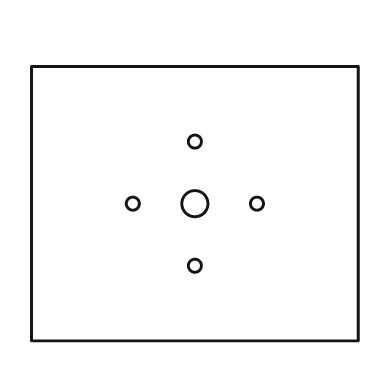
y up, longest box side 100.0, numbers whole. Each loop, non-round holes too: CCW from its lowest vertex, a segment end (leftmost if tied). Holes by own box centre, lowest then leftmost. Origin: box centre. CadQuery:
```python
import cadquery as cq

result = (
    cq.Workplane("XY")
    .moveTo(-50.0, -42.0)
    .lineTo(50.0, -42.0)
    .lineTo(50.0, 42.0)
    .lineTo(-50.0, 42.0)
    .close()
    .moveTo(0.0, -19.0)
    .circle(2.0)
    .moveTo(-19.0, 0.0)
    .circle(2.0)
    .moveTo(0.0, 0.0)
    .circle(4.0)
    .moveTo(19.0, 0.0)
    .circle(2.0)
    .moveTo(0.0, 19.0)
    .circle(2.0)
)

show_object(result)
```